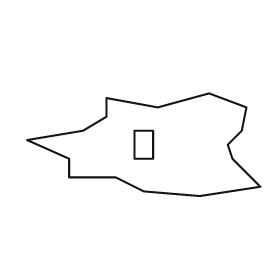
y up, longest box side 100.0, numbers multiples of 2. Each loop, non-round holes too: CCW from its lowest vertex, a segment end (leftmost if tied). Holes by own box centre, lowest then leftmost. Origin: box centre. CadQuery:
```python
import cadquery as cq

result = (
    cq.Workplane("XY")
    .moveTo(24.0, -22.0)
    .lineTo(50.0, -18.0)
    .lineTo(38.0, -6.0)
    .lineTo(36.0, 0.0)
    .lineTo(42.0, 6.0)
    .lineTo(44.0, 16.0)
    .lineTo(28.0, 22.0)
    .lineTo(6.0, 16.0)
    .lineTo(-16.0, 20.0)
    .lineTo(-16.0, 12.0)
    .lineTo(-26.0, 6.0)
    .lineTo(-50.0, 2.0)
    .lineTo(-32.0, -6.0)
    .lineTo(-32.0, -14.0)
    .lineTo(-12.0, -14.0)
    .lineTo(0.0, -20.0)
    .close()
    .moveTo(-4.0, -6.0)
    .lineTo(4.0, -6.0)
    .lineTo(4.0, 6.0)
    .lineTo(-4.0, 6.0)
    .close()
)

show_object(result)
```